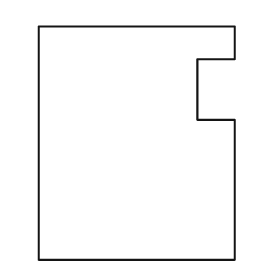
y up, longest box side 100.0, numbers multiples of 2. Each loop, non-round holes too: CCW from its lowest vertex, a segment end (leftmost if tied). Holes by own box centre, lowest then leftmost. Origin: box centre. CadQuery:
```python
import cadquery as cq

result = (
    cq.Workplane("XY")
    .moveTo(-42.0, -50.0)
    .lineTo(42.0, -50.0)
    .lineTo(42.0, 10.0)
    .lineTo(26.0, 10.0)
    .lineTo(26.0, 36.0)
    .lineTo(42.0, 36.0)
    .lineTo(42.0, 50.0)
    .lineTo(-42.0, 50.0)
    .close()
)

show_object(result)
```